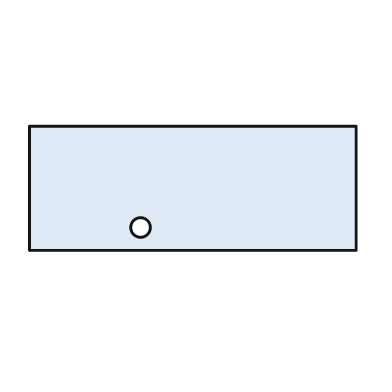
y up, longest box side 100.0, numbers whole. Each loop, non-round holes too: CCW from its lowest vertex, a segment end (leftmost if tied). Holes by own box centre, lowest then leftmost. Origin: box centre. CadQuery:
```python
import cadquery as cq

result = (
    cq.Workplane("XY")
    .moveTo(-50.0, -19.0)
    .lineTo(50.0, -19.0)
    .lineTo(50.0, 19.0)
    .lineTo(-50.0, 19.0)
    .close()
    .moveTo(-16.0, -12.0)
    .circle(3.0)
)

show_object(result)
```